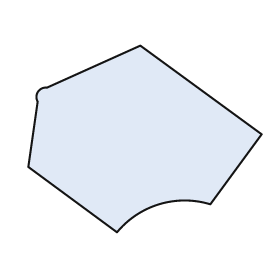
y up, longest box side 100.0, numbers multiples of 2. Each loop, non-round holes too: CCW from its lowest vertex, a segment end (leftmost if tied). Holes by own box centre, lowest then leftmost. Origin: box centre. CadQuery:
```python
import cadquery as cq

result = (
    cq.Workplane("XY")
    .moveTo(-12.0, -40.0)
    .threePointArc((6.0, -28.0), (28.0, -28.0))
    .lineTo(50.0, 2.0)
    .lineTo(-2.0, 40.0)
    .lineTo(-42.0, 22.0)
    .threePointArc((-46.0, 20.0), (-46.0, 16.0))
    .lineTo(-50.0, -12.0)
    .close()
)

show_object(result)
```